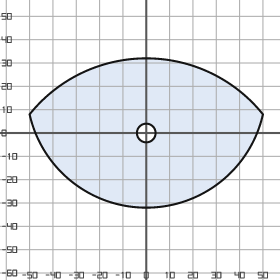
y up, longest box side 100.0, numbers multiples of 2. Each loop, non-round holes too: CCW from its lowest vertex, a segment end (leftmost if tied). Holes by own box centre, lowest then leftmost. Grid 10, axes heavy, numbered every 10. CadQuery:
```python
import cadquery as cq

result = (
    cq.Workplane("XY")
    .moveTo(-50.0, 8.0)
    .threePointArc((0.0, -32.0), (50.0, 8.0))
    .threePointArc((0.0, 32.0), (-50.0, 8.0))
    .close()
    .moveTo(0.0, 0.0)
    .circle(4.0)
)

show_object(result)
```